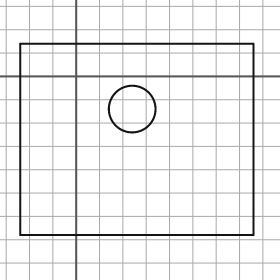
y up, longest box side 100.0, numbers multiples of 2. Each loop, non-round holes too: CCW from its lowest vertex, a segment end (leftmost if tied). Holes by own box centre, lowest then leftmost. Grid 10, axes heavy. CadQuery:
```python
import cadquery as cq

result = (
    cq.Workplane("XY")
    .moveTo(-24.0, -68.0)
    .lineTo(76.0, -68.0)
    .lineTo(76.0, 14.0)
    .lineTo(-24.0, 14.0)
    .close()
    .moveTo(24.0, -14.0)
    .circle(10.0)
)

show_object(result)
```